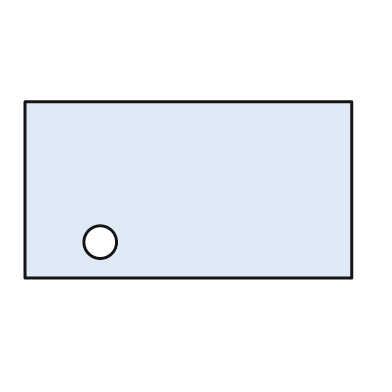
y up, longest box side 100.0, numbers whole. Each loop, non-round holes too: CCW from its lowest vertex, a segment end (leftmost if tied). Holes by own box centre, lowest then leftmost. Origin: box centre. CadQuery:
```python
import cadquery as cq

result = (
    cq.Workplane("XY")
    .moveTo(-50.0, -27.0)
    .lineTo(50.0, -27.0)
    .lineTo(50.0, 27.0)
    .lineTo(-50.0, 27.0)
    .close()
    .moveTo(-27.0, -16.0)
    .circle(5.0)
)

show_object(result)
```